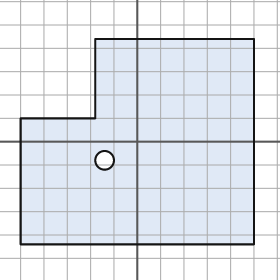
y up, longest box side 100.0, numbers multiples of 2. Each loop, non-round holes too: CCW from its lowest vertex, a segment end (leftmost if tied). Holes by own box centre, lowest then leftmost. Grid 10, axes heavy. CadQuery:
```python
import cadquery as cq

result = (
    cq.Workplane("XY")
    .moveTo(-50.0, -44.0)
    .lineTo(50.0, -44.0)
    .lineTo(50.0, 44.0)
    .lineTo(-18.0, 44.0)
    .lineTo(-18.0, 10.0)
    .lineTo(-50.0, 10.0)
    .close()
    .moveTo(-14.0, -8.0)
    .circle(4.0)
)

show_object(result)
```